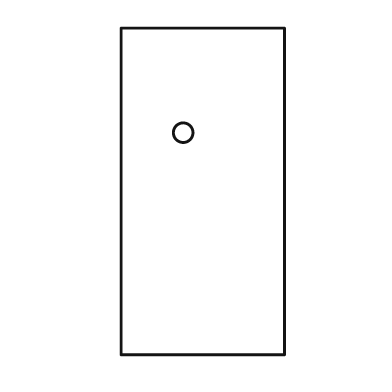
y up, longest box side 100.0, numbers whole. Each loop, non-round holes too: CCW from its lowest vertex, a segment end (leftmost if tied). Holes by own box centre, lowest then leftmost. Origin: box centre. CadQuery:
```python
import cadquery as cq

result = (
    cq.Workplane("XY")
    .moveTo(-25.0, -50.0)
    .lineTo(25.0, -50.0)
    .lineTo(25.0, 50.0)
    .lineTo(-25.0, 50.0)
    .close()
    .moveTo(-6.0, 18.0)
    .circle(3.0)
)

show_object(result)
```